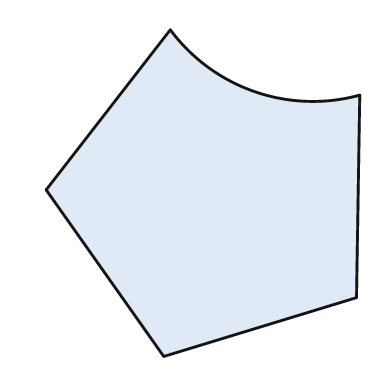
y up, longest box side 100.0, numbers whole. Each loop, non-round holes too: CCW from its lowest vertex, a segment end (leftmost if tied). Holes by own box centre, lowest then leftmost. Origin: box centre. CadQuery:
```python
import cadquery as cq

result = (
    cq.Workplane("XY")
    .moveTo(-12.0, -50.0)
    .lineTo(47.0, -32.0)
    .lineTo(48.0, 30.0)
    .threePointArc((16.0, 31.0), (-10.0, 50.0))
    .lineTo(-48.0, 1.0)
    .close()
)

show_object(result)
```